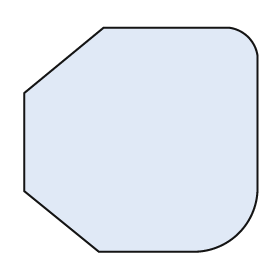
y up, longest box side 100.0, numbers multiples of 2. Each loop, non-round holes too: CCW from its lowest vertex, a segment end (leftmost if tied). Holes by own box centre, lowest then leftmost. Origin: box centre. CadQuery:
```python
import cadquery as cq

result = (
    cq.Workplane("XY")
    .moveTo(-18.0, -48.0)
    .lineTo(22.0, -48.0)
    .threePointArc((42.0, -40.0), (50.0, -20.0))
    .lineTo(50.0, 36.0)
    .threePointArc((46.0, 44.0), (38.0, 48.0))
    .lineTo(-16.0, 48.0)
    .lineTo(-50.0, 20.0)
    .lineTo(-50.0, -22.0)
    .close()
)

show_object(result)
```